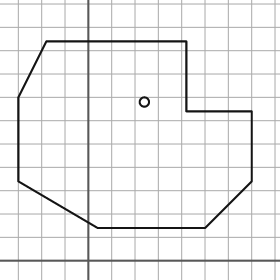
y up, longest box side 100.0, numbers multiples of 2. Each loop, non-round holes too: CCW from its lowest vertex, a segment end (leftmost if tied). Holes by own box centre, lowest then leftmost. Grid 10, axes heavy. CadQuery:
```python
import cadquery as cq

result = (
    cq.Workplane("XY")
    .moveTo(4.0, 14.0)
    .lineTo(50.0, 14.0)
    .lineTo(70.0, 34.0)
    .lineTo(70.0, 64.0)
    .lineTo(42.0, 64.0)
    .lineTo(42.0, 94.0)
    .lineTo(-18.0, 94.0)
    .lineTo(-30.0, 70.0)
    .lineTo(-30.0, 34.0)
    .close()
    .moveTo(24.0, 68.0)
    .circle(2.0)
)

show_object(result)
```